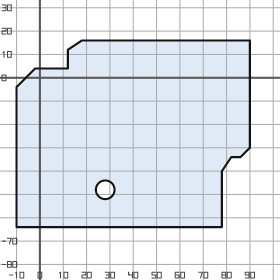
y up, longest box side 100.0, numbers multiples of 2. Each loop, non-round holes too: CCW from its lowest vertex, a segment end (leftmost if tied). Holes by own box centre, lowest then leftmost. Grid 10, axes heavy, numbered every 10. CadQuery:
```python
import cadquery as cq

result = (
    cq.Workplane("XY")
    .moveTo(-10.0, -64.0)
    .lineTo(78.0, -64.0)
    .lineTo(78.0, -40.0)
    .lineTo(82.0, -34.0)
    .lineTo(86.0, -34.0)
    .lineTo(90.0, -30.0)
    .lineTo(90.0, 16.0)
    .lineTo(18.0, 16.0)
    .lineTo(12.0, 12.0)
    .lineTo(12.0, 4.0)
    .lineTo(-2.0, 4.0)
    .lineTo(-10.0, -4.0)
    .close()
    .moveTo(28.0, -48.0)
    .circle(4.0)
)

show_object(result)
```